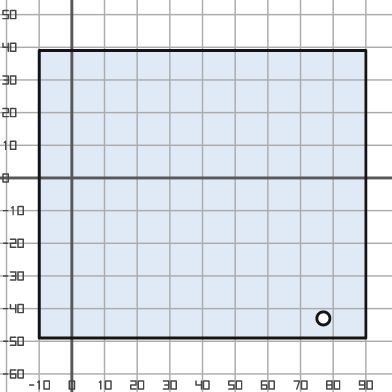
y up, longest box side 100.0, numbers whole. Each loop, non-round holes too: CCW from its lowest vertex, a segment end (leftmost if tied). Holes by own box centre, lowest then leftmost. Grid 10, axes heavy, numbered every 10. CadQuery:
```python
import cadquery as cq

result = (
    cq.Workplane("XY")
    .moveTo(-10.0, -49.0)
    .lineTo(90.0, -49.0)
    .lineTo(90.0, 39.0)
    .lineTo(-10.0, 39.0)
    .close()
    .moveTo(77.0, -43.0)
    .circle(2.0)
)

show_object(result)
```